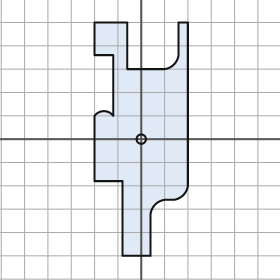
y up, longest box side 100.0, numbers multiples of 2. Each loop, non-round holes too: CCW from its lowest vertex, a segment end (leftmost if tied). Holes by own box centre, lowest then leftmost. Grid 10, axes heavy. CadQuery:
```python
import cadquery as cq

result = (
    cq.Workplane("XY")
    .moveTo(-8.0, -50.0)
    .lineTo(4.0, -50.0)
    .lineTo(4.0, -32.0)
    .threePointArc((6.0, -28.0), (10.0, -26.0))
    .lineTo(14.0, -26.0)
    .threePointArc((18.0, -24.0), (20.0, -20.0))
    .lineTo(20.0, 50.0)
    .lineTo(16.0, 50.0)
    .lineTo(16.0, 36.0)
    .threePointArc((14.0, 32.0), (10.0, 30.0))
    .lineTo(-6.0, 30.0)
    .lineTo(-6.0, 50.0)
    .lineTo(-20.0, 50.0)
    .lineTo(-20.0, 36.0)
    .lineTo(-12.0, 36.0)
    .lineTo(-12.0, 10.0)
    .threePointArc((-16.0, 12.0), (-20.0, 10.0))
    .lineTo(-20.0, -18.0)
    .lineTo(-8.0, -18.0)
    .close()
    .moveTo(0.0, 0.0)
    .circle(2.0)
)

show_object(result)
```